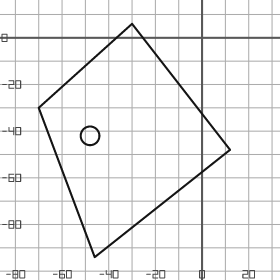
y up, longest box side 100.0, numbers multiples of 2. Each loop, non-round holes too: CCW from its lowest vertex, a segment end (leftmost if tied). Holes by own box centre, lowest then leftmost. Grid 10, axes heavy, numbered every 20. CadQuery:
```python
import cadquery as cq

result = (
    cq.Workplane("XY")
    .moveTo(-46.0, -94.0)
    .lineTo(12.0, -48.0)
    .lineTo(-30.0, 6.0)
    .lineTo(-70.0, -30.0)
    .close()
    .moveTo(-48.0, -42.0)
    .circle(4.0)
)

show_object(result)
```